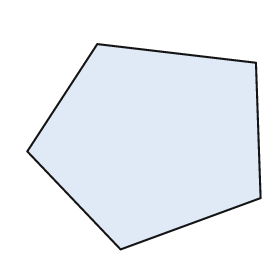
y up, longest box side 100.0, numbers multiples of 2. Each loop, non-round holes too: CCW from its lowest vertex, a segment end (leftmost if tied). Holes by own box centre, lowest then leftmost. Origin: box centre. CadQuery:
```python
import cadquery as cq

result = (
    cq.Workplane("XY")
    .moveTo(-10.0, -44.0)
    .lineTo(50.0, -22.0)
    .lineTo(48.0, 36.0)
    .lineTo(-20.0, 44.0)
    .lineTo(-50.0, -2.0)
    .close()
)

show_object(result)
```